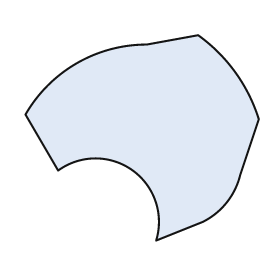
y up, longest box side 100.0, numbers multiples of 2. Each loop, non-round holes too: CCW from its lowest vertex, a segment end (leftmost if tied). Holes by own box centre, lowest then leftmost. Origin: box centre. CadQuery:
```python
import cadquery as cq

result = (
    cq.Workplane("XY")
    .moveTo(6.0, -44.0)
    .lineTo(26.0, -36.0)
    .threePointArc((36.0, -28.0), (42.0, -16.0))
    .lineTo(50.0, 8.0)
    .threePointArc((40.0, 28.0), (24.0, 44.0))
    .lineTo(2.0, 40.0)
    .threePointArc((-28.0, 32.0), (-50.0, 10.0))
    .lineTo(-36.0, -14.0)
    .threePointArc((-4.0, -14.0), (6.0, -44.0))
    .close()
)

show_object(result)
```